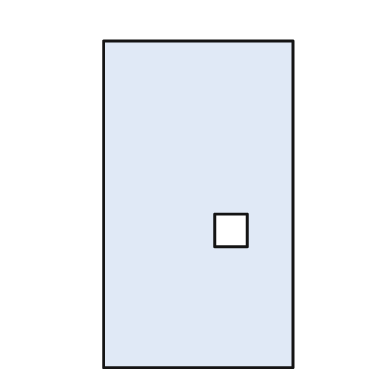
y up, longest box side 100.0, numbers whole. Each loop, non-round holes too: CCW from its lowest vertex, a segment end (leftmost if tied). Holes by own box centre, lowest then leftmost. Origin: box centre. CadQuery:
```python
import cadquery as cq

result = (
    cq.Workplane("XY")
    .moveTo(-29.0, -50.0)
    .lineTo(29.0, -50.0)
    .lineTo(29.0, 50.0)
    .lineTo(-29.0, 50.0)
    .close()
    .moveTo(5.0, -13.0)
    .lineTo(15.0, -13.0)
    .lineTo(15.0, -3.0)
    .lineTo(5.0, -3.0)
    .close()
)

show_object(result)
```